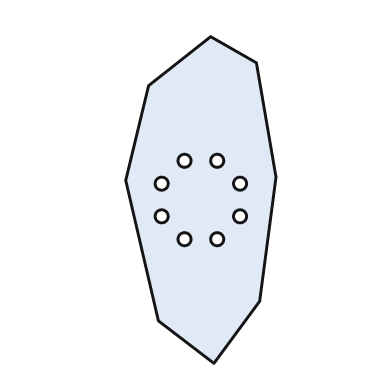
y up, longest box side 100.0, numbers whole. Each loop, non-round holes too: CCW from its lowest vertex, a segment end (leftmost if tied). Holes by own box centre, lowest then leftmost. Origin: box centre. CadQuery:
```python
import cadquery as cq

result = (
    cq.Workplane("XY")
    .moveTo(4.0, -50.0)
    .lineTo(18.0, -31.0)
    .lineTo(23.0, 7.0)
    .lineTo(17.0, 42.0)
    .lineTo(3.0, 50.0)
    .lineTo(-16.0, 35.0)
    .lineTo(-23.0, 6.0)
    .lineTo(-13.0, -37.0)
    .close()
    .moveTo(-5.0, -12.0)
    .circle(2.0)
    .moveTo(5.0, -12.0)
    .circle(2.0)
    .moveTo(-12.0, -5.0)
    .circle(2.0)
    .moveTo(12.0, -5.0)
    .circle(2.0)
    .moveTo(-12.0, 5.0)
    .circle(2.0)
    .moveTo(12.0, 5.0)
    .circle(2.0)
    .moveTo(-5.0, 12.0)
    .circle(2.0)
    .moveTo(5.0, 12.0)
    .circle(2.0)
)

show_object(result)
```